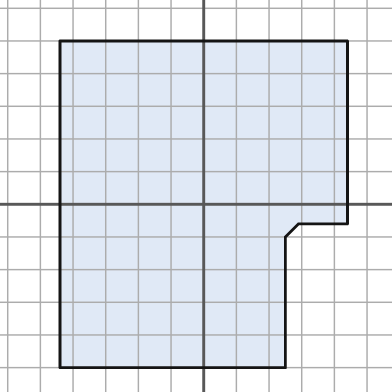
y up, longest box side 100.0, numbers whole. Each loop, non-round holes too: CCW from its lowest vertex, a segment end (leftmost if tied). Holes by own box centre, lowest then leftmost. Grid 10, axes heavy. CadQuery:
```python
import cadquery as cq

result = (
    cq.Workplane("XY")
    .moveTo(-44.0, -50.0)
    .lineTo(25.0, -50.0)
    .lineTo(25.0, -10.0)
    .lineTo(29.0, -6.0)
    .lineTo(44.0, -6.0)
    .lineTo(44.0, 50.0)
    .lineTo(-44.0, 50.0)
    .close()
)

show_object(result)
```